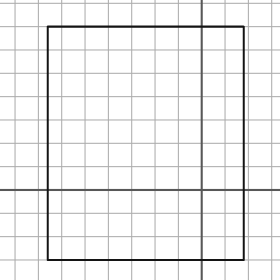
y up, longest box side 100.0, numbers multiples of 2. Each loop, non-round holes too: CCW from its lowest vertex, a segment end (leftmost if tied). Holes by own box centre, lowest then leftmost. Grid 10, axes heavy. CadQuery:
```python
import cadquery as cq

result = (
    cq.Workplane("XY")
    .moveTo(-66.0, -30.0)
    .lineTo(18.0, -30.0)
    .lineTo(18.0, 70.0)
    .lineTo(-66.0, 70.0)
    .close()
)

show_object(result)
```